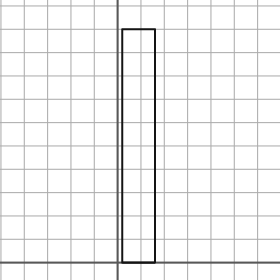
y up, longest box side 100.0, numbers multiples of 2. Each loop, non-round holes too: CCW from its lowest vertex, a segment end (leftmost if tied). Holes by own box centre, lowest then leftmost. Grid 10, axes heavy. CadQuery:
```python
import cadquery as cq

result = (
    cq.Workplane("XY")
    .moveTo(2.0, 0.0)
    .lineTo(16.0, 0.0)
    .lineTo(16.0, 100.0)
    .lineTo(2.0, 100.0)
    .close()
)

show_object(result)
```